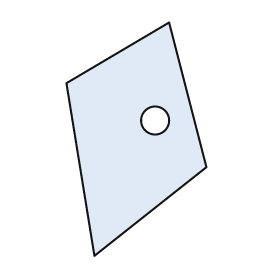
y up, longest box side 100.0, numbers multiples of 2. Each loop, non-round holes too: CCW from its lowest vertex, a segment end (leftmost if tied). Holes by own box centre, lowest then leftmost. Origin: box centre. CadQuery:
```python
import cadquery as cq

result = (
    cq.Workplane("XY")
    .moveTo(-18.0, -50.0)
    .lineTo(30.0, -12.0)
    .lineTo(14.0, 50.0)
    .lineTo(-30.0, 24.0)
    .close()
    .moveTo(8.0, 8.0)
    .circle(6.0)
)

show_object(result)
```